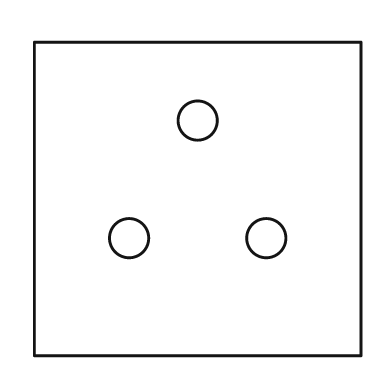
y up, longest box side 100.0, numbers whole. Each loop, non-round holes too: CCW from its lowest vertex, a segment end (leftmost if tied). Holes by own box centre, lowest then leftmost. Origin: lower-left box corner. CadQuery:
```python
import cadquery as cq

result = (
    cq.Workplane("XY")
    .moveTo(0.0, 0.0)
    .lineTo(100.0, 0.0)
    .lineTo(100.0, 96.0)
    .lineTo(0.0, 96.0)
    .close()
    .moveTo(29.0, 36.0)
    .circle(6.0)
    .moveTo(71.0, 36.0)
    .circle(6.0)
    .moveTo(50.0, 72.0)
    .circle(6.0)
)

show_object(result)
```